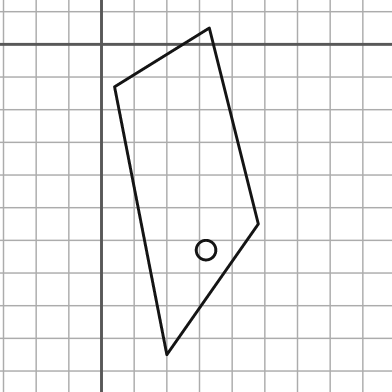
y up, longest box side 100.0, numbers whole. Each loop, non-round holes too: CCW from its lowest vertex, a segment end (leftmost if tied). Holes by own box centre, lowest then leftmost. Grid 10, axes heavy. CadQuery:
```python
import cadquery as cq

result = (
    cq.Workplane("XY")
    .moveTo(20.0, -95.0)
    .lineTo(48.0, -55.0)
    .lineTo(33.0, 5.0)
    .lineTo(4.0, -13.0)
    .close()
    .moveTo(32.0, -63.0)
    .circle(3.0)
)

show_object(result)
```